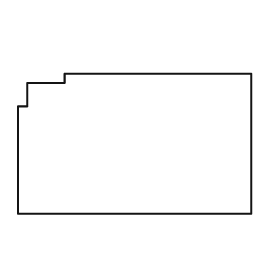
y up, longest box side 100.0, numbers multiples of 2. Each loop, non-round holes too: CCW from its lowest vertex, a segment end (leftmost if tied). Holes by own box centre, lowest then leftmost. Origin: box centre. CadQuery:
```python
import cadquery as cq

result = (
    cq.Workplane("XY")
    .moveTo(-50.0, -30.0)
    .lineTo(50.0, -30.0)
    .lineTo(50.0, 30.0)
    .lineTo(-30.0, 30.0)
    .lineTo(-30.0, 26.0)
    .lineTo(-46.0, 26.0)
    .lineTo(-46.0, 16.0)
    .lineTo(-50.0, 16.0)
    .close()
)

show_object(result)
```